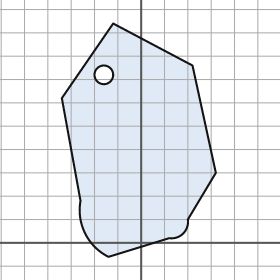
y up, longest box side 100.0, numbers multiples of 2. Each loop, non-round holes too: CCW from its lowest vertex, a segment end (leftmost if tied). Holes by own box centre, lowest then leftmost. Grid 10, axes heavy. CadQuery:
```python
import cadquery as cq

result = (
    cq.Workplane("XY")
    .moveTo(-14.0, -6.0)
    .lineTo(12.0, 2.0)
    .threePointArc((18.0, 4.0), (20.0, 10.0))
    .lineTo(32.0, 30.0)
    .lineTo(22.0, 76.0)
    .lineTo(-12.0, 94.0)
    .lineTo(-34.0, 62.0)
    .lineTo(-26.0, 18.0)
    .threePointArc((-24.0, 4.0), (-14.0, -6.0))
    .close()
    .moveTo(-16.0, 72.0)
    .circle(4.0)
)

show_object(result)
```